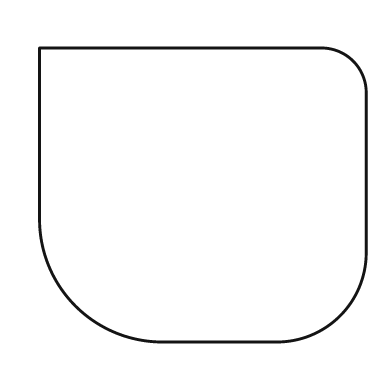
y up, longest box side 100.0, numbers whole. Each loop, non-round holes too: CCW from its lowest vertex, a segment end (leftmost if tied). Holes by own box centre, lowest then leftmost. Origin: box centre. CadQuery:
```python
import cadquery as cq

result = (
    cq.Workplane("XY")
    .moveTo(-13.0, -45.0)
    .lineTo(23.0, -45.0)
    .threePointArc((42.0, -37.0), (50.0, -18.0))
    .lineTo(50.0, 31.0)
    .threePointArc((46.0, 41.0), (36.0, 45.0))
    .lineTo(-50.0, 45.0)
    .lineTo(-50.0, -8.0)
    .threePointArc((-39.0, -34.0), (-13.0, -45.0))
    .close()
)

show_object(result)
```